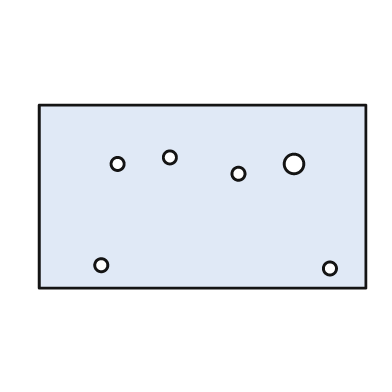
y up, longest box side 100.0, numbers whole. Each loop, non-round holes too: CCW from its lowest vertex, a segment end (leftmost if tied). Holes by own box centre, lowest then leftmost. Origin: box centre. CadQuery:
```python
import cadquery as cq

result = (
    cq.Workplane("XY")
    .moveTo(-50.0, -28.0)
    .lineTo(50.0, -28.0)
    .lineTo(50.0, 28.0)
    .lineTo(-50.0, 28.0)
    .close()
    .moveTo(39.0, -22.0)
    .circle(2.0)
    .moveTo(-31.0, -21.0)
    .circle(2.0)
    .moveTo(11.0, 7.0)
    .circle(2.0)
    .moveTo(-26.0, 10.0)
    .circle(2.0)
    .moveTo(28.0, 10.0)
    .circle(3.0)
    .moveTo(-10.0, 12.0)
    .circle(2.0)
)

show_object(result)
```